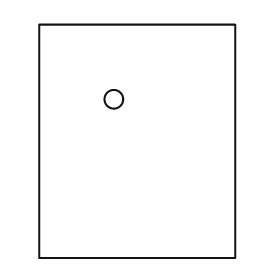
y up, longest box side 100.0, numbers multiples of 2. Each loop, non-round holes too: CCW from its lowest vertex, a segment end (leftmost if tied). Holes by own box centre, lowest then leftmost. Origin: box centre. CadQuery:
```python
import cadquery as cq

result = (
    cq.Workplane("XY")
    .moveTo(-42.0, -50.0)
    .lineTo(42.0, -50.0)
    .lineTo(42.0, 50.0)
    .lineTo(-42.0, 50.0)
    .close()
    .moveTo(-10.0, 18.0)
    .circle(4.0)
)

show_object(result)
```